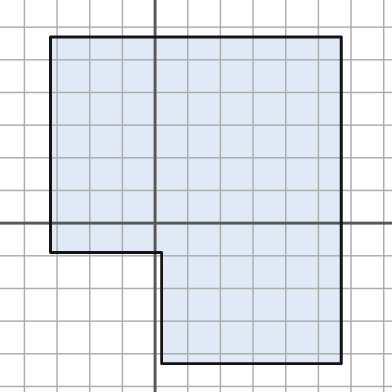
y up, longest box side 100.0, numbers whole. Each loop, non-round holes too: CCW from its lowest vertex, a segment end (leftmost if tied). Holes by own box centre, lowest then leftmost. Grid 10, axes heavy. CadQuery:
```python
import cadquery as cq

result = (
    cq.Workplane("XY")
    .moveTo(2.0, -43.0)
    .lineTo(57.0, -43.0)
    .lineTo(57.0, 57.0)
    .lineTo(-32.0, 57.0)
    .lineTo(-32.0, -9.0)
    .lineTo(2.0, -9.0)
    .close()
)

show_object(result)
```